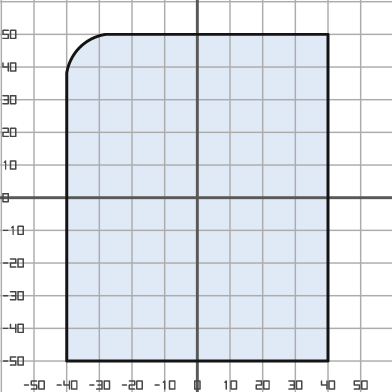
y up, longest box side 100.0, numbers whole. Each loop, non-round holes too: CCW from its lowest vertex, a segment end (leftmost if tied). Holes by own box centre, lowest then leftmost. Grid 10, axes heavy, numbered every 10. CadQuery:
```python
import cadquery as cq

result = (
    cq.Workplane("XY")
    .moveTo(-40.0, -50.0)
    .lineTo(40.0, -50.0)
    .lineTo(40.0, 50.0)
    .lineTo(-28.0, 50.0)
    .threePointArc((-36.0, 46.0), (-40.0, 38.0))
    .close()
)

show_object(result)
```